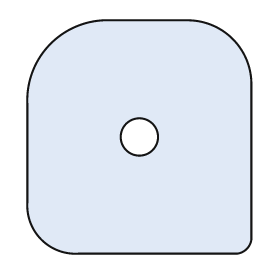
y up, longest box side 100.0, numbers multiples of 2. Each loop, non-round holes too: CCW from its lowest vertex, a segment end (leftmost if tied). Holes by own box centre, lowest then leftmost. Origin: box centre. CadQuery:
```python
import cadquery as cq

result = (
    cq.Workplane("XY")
    .moveTo(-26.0, -50.0)
    .lineTo(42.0, -50.0)
    .threePointArc((46.0, -48.0), (48.0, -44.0))
    .lineTo(48.0, 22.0)
    .threePointArc((40.0, 42.0), (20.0, 50.0))
    .lineTo(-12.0, 50.0)
    .threePointArc((-38.0, 40.0), (-48.0, 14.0))
    .lineTo(-48.0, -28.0)
    .threePointArc((-42.0, -44.0), (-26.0, -50.0))
    .close()
    .moveTo(0.0, 0.0)
    .circle(8.0)
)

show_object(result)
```